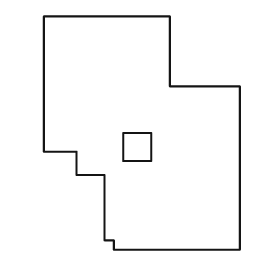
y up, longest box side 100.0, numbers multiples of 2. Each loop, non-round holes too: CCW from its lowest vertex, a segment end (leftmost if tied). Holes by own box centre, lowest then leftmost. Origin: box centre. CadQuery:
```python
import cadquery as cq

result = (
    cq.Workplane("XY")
    .moveTo(-12.0, -50.0)
    .lineTo(42.0, -50.0)
    .lineTo(42.0, 20.0)
    .lineTo(12.0, 20.0)
    .lineTo(12.0, 50.0)
    .lineTo(-42.0, 50.0)
    .lineTo(-42.0, -8.0)
    .lineTo(-28.0, -8.0)
    .lineTo(-28.0, -18.0)
    .lineTo(-16.0, -18.0)
    .lineTo(-16.0, -46.0)
    .lineTo(-12.0, -46.0)
    .close()
    .moveTo(-8.0, -12.0)
    .lineTo(4.0, -12.0)
    .lineTo(4.0, 0.0)
    .lineTo(-8.0, 0.0)
    .close()
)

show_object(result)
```